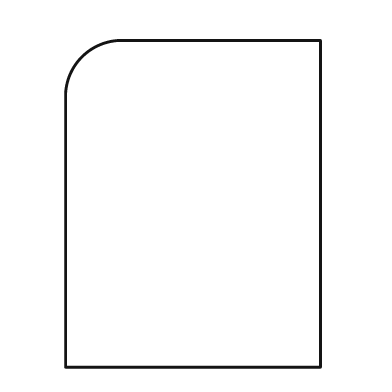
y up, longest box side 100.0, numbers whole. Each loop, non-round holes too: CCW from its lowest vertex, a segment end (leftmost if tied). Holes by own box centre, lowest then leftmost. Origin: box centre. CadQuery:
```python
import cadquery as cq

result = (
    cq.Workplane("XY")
    .moveTo(-39.0, -50.0)
    .lineTo(39.0, -50.0)
    .lineTo(39.0, 50.0)
    .lineTo(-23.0, 50.0)
    .threePointArc((-34.0, 45.0), (-39.0, 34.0))
    .close()
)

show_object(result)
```